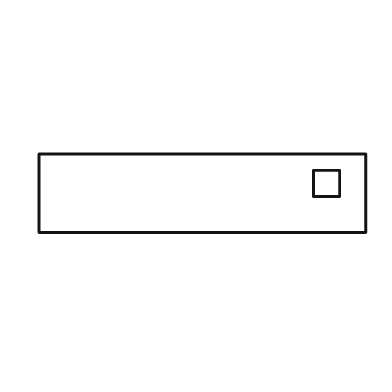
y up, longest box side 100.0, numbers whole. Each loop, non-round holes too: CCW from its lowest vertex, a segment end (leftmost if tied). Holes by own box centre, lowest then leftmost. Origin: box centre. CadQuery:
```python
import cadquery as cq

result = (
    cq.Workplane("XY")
    .moveTo(-50.0, -12.0)
    .lineTo(50.0, -12.0)
    .lineTo(50.0, 12.0)
    .lineTo(-50.0, 12.0)
    .close()
    .moveTo(34.0, -1.0)
    .lineTo(42.0, -1.0)
    .lineTo(42.0, 7.0)
    .lineTo(34.0, 7.0)
    .close()
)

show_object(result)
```